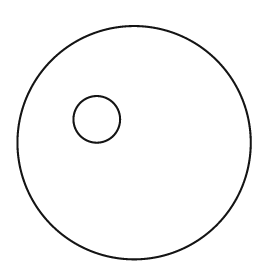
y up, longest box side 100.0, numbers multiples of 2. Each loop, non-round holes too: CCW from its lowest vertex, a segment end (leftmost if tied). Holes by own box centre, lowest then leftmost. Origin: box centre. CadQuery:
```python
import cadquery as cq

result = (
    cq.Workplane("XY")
    .moveTo(0.0, 0.0)
    .circle(50.0)
    .moveTo(-16.0, 10.0)
    .circle(10.0)
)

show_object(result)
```